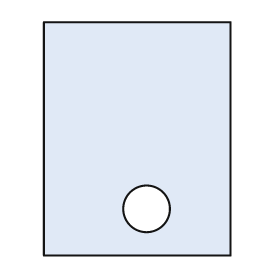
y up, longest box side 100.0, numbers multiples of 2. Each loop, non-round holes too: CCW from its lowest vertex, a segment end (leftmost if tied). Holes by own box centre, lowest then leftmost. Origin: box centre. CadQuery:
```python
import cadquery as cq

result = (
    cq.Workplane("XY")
    .moveTo(-40.0, -50.0)
    .lineTo(40.0, -50.0)
    .lineTo(40.0, 50.0)
    .lineTo(-40.0, 50.0)
    .close()
    .moveTo(4.0, -30.0)
    .circle(10.0)
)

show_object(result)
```